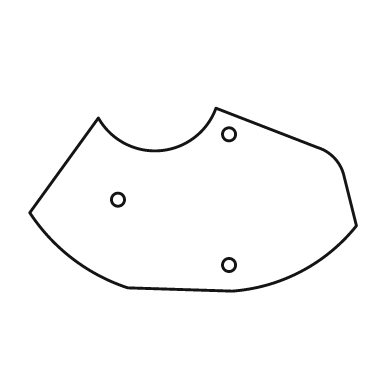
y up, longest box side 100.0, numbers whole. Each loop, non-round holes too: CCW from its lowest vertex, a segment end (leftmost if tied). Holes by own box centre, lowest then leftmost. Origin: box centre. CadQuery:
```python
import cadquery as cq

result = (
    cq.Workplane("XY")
    .moveTo(12.0, -28.0)
    .threePointArc((33.0, -22.0), (50.0, -8.0))
    .lineTo(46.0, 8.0)
    .threePointArc((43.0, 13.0), (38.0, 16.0))
    .lineTo(7.0, 28.0)
    .threePointArc((-10.0, 15.0), (-29.0, 25.0))
    .lineTo(-50.0, -4.0)
    .threePointArc((-37.0, -18.0), (-20.0, -27.0))
    .close()
    .moveTo(11.0, -20.0)
    .circle(2.0)
    .moveTo(-23.0, 0.0)
    .circle(2.0)
    .moveTo(11.0, 20.0)
    .circle(2.0)
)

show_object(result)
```